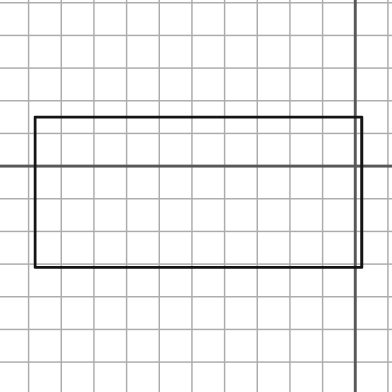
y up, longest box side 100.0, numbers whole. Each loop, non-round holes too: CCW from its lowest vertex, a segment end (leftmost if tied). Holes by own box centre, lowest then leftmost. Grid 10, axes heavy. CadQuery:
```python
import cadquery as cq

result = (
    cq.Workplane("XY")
    .moveTo(-98.0, -31.0)
    .lineTo(2.0, -31.0)
    .lineTo(2.0, 15.0)
    .lineTo(-98.0, 15.0)
    .close()
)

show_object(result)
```